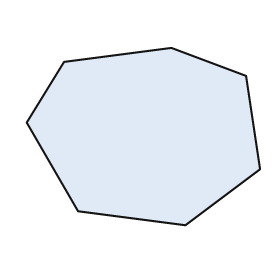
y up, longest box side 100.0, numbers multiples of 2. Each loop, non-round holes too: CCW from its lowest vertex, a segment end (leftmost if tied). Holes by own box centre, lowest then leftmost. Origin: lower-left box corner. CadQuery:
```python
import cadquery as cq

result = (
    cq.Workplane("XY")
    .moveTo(68.0, 0.0)
    .lineTo(100.0, 24.0)
    .lineTo(94.0, 64.0)
    .lineTo(62.0, 76.0)
    .lineTo(16.0, 70.0)
    .lineTo(0.0, 44.0)
    .lineTo(22.0, 6.0)
    .close()
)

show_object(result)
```